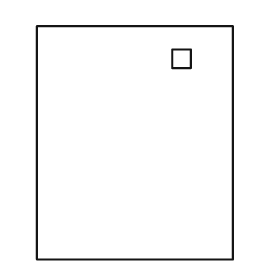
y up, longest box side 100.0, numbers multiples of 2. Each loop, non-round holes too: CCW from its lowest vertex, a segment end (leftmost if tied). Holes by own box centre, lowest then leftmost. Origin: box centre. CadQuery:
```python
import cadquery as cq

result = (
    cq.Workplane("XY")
    .moveTo(-42.0, -50.0)
    .lineTo(42.0, -50.0)
    .lineTo(42.0, 50.0)
    .lineTo(-42.0, 50.0)
    .close()
    .moveTo(16.0, 32.0)
    .lineTo(24.0, 32.0)
    .lineTo(24.0, 40.0)
    .lineTo(16.0, 40.0)
    .close()
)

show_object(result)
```